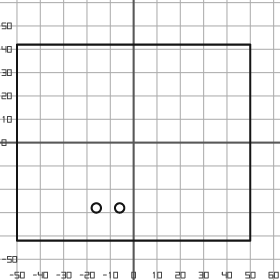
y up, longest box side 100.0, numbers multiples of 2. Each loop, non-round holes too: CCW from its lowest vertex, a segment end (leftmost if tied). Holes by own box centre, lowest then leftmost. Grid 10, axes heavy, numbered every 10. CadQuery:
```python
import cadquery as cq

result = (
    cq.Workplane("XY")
    .moveTo(-50.0, -42.0)
    .lineTo(50.0, -42.0)
    .lineTo(50.0, 42.0)
    .lineTo(-50.0, 42.0)
    .close()
    .moveTo(-16.0, -28.0)
    .circle(2.0)
    .moveTo(-6.0, -28.0)
    .circle(2.0)
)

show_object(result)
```